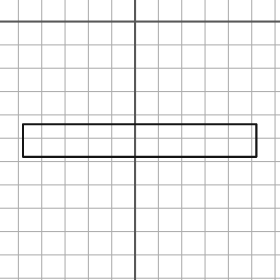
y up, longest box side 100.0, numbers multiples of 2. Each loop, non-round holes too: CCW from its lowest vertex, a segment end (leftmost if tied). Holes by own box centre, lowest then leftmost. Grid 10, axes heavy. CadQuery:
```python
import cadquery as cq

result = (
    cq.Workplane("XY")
    .moveTo(-48.0, -58.0)
    .lineTo(52.0, -58.0)
    .lineTo(52.0, -44.0)
    .lineTo(-48.0, -44.0)
    .close()
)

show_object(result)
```